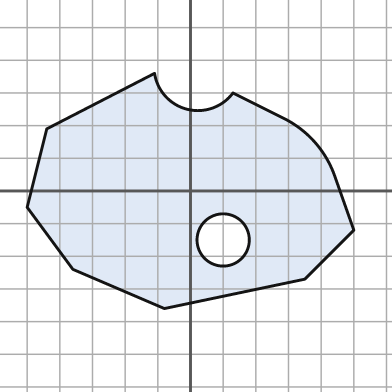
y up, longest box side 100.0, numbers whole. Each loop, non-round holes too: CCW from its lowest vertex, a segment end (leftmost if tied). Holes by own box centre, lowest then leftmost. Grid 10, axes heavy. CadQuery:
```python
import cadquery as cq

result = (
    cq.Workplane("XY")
    .moveTo(-8.0, -36.0)
    .lineTo(35.0, -27.0)
    .lineTo(50.0, -12.0)
    .lineTo(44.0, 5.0)
    .threePointArc((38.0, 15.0), (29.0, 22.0))
    .lineTo(13.0, 30.0)
    .threePointArc((-1.0, 25.0), (-11.0, 36.0))
    .lineTo(-44.0, 19.0)
    .lineTo(-50.0, -5.0)
    .lineTo(-36.0, -24.0)
    .close()
    .moveTo(10.0, -15.0)
    .circle(8.0)
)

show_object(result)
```